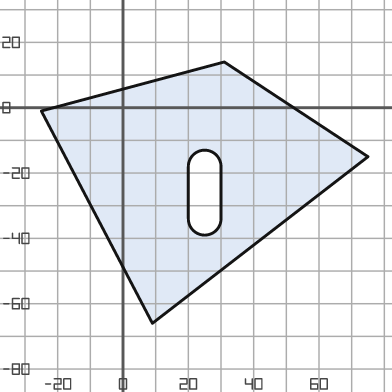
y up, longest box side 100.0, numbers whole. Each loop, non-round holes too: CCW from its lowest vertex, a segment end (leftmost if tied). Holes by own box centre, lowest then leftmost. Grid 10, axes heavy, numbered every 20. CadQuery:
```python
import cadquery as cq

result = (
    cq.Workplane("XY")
    .moveTo(9.0, -66.0)
    .lineTo(75.0, -15.0)
    .lineTo(31.0, 14.0)
    .lineTo(-25.0, -1.0)
    .close()
    .moveTo(20.0, -34.0)
    .threePointArc((25.0, -39.0), (30.0, -34.0))
    .lineTo(30.0, -18.0)
    .threePointArc((25.0, -13.0), (20.0, -18.0))
    .close()
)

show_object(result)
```